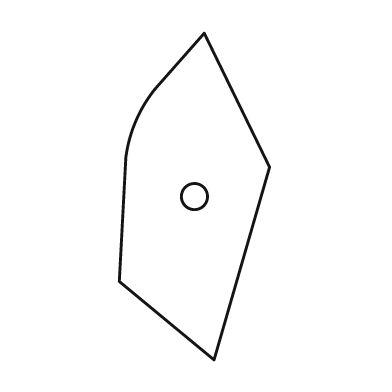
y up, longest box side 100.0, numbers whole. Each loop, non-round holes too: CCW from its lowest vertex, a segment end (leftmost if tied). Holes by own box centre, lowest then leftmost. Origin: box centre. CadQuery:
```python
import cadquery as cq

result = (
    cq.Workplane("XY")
    .moveTo(6.0, -50.0)
    .lineTo(23.0, 9.0)
    .lineTo(3.0, 50.0)
    .lineTo(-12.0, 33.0)
    .threePointArc((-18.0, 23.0), (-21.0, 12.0))
    .lineTo(-23.0, -26.0)
    .close()
    .moveTo(0.0, 0.0)
    .circle(4.0)
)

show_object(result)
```